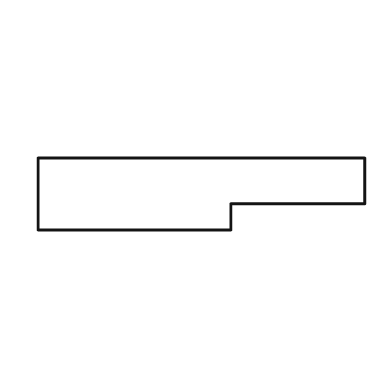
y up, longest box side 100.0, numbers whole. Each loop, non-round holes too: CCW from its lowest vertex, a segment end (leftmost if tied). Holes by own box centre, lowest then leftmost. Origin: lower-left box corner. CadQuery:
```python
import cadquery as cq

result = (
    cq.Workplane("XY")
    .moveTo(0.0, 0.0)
    .lineTo(59.0, 0.0)
    .lineTo(59.0, 8.0)
    .lineTo(100.0, 8.0)
    .lineTo(100.0, 22.0)
    .lineTo(0.0, 22.0)
    .close()
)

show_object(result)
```